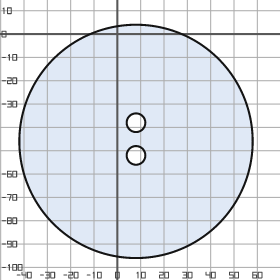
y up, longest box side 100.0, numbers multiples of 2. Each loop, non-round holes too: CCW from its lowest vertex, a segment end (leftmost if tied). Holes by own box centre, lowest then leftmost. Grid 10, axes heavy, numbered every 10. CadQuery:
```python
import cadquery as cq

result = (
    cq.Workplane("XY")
    .moveTo(8.0, -46.0)
    .circle(50.0)
    .moveTo(8.0, -52.0)
    .circle(4.0)
    .moveTo(8.0, -38.0)
    .circle(4.0)
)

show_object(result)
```